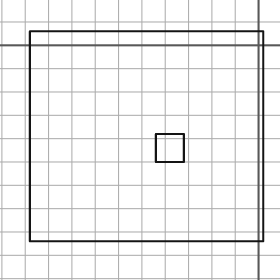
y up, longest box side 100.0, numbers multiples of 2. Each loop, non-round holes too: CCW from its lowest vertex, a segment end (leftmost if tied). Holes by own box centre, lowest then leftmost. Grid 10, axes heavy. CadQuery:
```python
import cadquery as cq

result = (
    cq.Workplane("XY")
    .moveTo(-98.0, -84.0)
    .lineTo(2.0, -84.0)
    .lineTo(2.0, 6.0)
    .lineTo(-98.0, 6.0)
    .close()
    .moveTo(-44.0, -50.0)
    .lineTo(-32.0, -50.0)
    .lineTo(-32.0, -38.0)
    .lineTo(-44.0, -38.0)
    .close()
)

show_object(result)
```